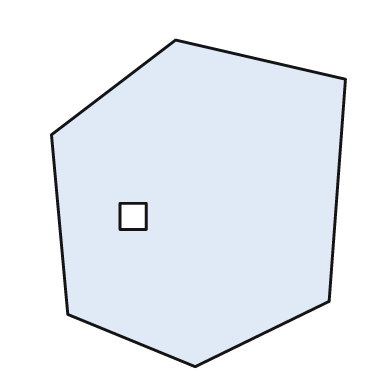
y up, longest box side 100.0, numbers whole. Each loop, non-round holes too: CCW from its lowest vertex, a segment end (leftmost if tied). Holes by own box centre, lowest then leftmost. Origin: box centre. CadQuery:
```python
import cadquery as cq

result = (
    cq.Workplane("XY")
    .moveTo(-1.0, -50.0)
    .lineTo(40.0, -30.0)
    .lineTo(45.0, 38.0)
    .lineTo(-7.0, 50.0)
    .lineTo(-45.0, 21.0)
    .lineTo(-40.0, -34.0)
    .close()
    .moveTo(-24.0, -8.0)
    .lineTo(-16.0, -8.0)
    .lineTo(-16.0, 0.0)
    .lineTo(-24.0, 0.0)
    .close()
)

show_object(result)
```